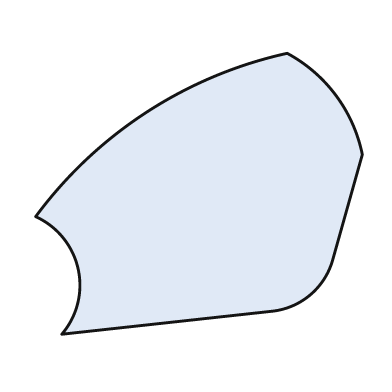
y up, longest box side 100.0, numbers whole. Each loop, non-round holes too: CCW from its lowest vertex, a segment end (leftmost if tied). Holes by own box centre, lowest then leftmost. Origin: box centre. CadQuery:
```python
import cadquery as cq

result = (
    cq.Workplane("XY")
    .moveTo(-42.0, -43.0)
    .lineTo(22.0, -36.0)
    .threePointArc((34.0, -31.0), (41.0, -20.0))
    .lineTo(50.0, 12.0)
    .threePointArc((42.0, 30.0), (27.0, 43.0))
    .threePointArc((-16.0, 25.0), (-50.0, -7.0))
    .threePointArc((-37.0, -23.0), (-42.0, -43.0))
    .close()
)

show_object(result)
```